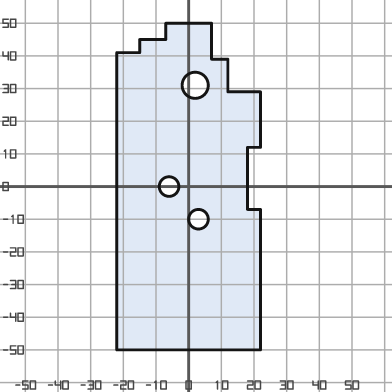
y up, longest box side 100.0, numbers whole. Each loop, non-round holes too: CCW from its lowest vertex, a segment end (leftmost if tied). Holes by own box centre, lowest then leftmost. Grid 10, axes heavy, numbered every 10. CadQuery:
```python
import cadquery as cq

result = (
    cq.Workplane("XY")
    .moveTo(-22.0, -50.0)
    .lineTo(22.0, -50.0)
    .lineTo(22.0, -7.0)
    .lineTo(18.0, -7.0)
    .lineTo(18.0, 12.0)
    .lineTo(22.0, 12.0)
    .lineTo(22.0, 29.0)
    .lineTo(12.0, 29.0)
    .lineTo(12.0, 39.0)
    .lineTo(7.0, 39.0)
    .lineTo(7.0, 50.0)
    .lineTo(-7.0, 50.0)
    .lineTo(-7.0, 45.0)
    .lineTo(-15.0, 45.0)
    .lineTo(-15.0, 41.0)
    .lineTo(-22.0, 41.0)
    .close()
    .moveTo(3.0, -10.0)
    .circle(3.0)
    .moveTo(-6.0, 0.0)
    .circle(3.0)
    .moveTo(2.0, 31.0)
    .circle(4.0)
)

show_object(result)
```